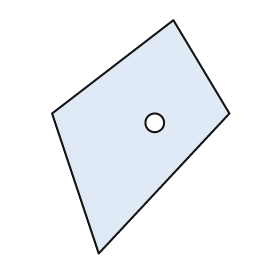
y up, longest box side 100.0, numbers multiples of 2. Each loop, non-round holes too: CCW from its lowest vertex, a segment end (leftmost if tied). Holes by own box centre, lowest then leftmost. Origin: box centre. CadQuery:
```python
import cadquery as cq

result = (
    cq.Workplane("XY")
    .moveTo(-18.0, -50.0)
    .lineTo(38.0, 10.0)
    .lineTo(14.0, 50.0)
    .lineTo(-38.0, 10.0)
    .close()
    .moveTo(6.0, 6.0)
    .circle(4.0)
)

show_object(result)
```